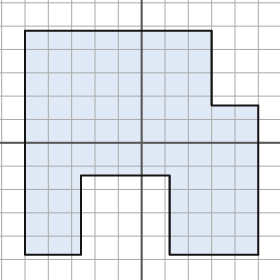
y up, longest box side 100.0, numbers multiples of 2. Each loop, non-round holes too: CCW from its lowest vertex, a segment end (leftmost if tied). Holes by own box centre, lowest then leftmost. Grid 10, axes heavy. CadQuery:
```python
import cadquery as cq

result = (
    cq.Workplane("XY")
    .moveTo(-50.0, -48.0)
    .lineTo(-26.0, -48.0)
    .lineTo(-26.0, -14.0)
    .lineTo(12.0, -14.0)
    .lineTo(12.0, -48.0)
    .lineTo(50.0, -48.0)
    .lineTo(50.0, 16.0)
    .lineTo(30.0, 16.0)
    .lineTo(30.0, 48.0)
    .lineTo(-50.0, 48.0)
    .close()
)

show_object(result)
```